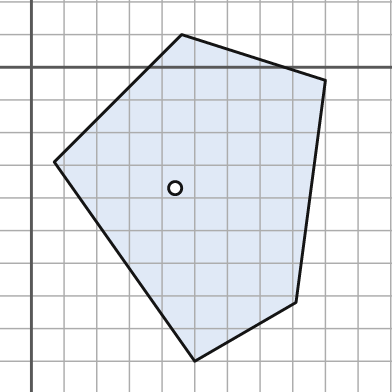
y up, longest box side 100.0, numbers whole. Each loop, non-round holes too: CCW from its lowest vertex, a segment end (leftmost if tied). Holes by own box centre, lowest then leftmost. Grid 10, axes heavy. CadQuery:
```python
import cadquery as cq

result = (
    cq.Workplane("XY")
    .moveTo(50.0, -90.0)
    .lineTo(81.0, -72.0)
    .lineTo(90.0, -4.0)
    .lineTo(46.0, 10.0)
    .lineTo(7.0, -29.0)
    .close()
    .moveTo(44.0, -37.0)
    .circle(2.0)
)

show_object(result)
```